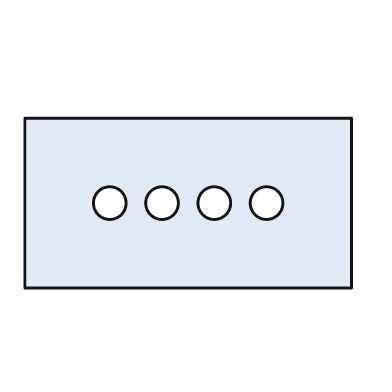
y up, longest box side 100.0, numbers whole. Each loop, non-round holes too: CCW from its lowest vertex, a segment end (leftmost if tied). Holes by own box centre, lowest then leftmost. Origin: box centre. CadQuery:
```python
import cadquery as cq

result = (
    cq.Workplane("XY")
    .moveTo(-50.0, -26.0)
    .lineTo(50.0, -26.0)
    .lineTo(50.0, 26.0)
    .lineTo(-50.0, 26.0)
    .close()
    .moveTo(-24.0, 0.0)
    .circle(5.0)
    .moveTo(-8.0, 0.0)
    .circle(5.0)
    .moveTo(8.0, 0.0)
    .circle(5.0)
    .moveTo(24.0, 0.0)
    .circle(5.0)
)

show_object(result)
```